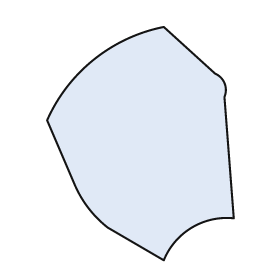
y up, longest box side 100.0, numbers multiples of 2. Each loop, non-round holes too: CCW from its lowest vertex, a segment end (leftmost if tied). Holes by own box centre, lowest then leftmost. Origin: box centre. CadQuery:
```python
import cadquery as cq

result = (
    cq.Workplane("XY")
    .moveTo(10.0, -50.0)
    .threePointArc((22.0, -36.0), (40.0, -32.0))
    .lineTo(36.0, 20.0)
    .threePointArc((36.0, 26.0), (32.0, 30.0))
    .lineTo(10.0, 50.0)
    .threePointArc((-20.0, 36.0), (-40.0, 10.0))
    .lineTo(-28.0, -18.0)
    .threePointArc((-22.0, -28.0), (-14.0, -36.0))
    .close()
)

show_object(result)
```